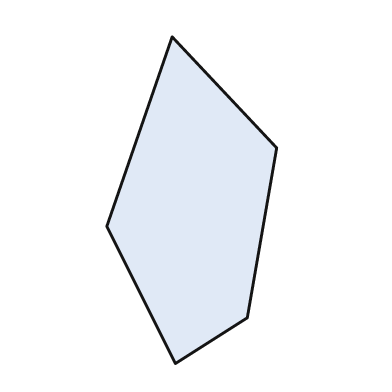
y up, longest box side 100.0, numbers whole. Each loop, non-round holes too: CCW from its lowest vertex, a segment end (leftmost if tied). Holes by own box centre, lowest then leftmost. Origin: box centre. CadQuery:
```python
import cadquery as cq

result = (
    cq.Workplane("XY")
    .moveTo(-5.0, -50.0)
    .lineTo(17.0, -36.0)
    .lineTo(26.0, 16.0)
    .lineTo(-6.0, 50.0)
    .lineTo(-26.0, -8.0)
    .close()
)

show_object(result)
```